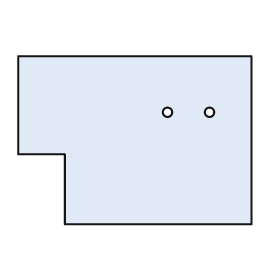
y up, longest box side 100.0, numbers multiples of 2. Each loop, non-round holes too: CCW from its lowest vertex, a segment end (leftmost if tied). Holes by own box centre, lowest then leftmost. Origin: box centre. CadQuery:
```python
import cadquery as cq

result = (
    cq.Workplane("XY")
    .moveTo(-30.0, -36.0)
    .lineTo(50.0, -36.0)
    .lineTo(50.0, 36.0)
    .lineTo(-50.0, 36.0)
    .lineTo(-50.0, -6.0)
    .lineTo(-30.0, -6.0)
    .close()
    .moveTo(14.0, 12.0)
    .circle(2.0)
    .moveTo(32.0, 12.0)
    .circle(2.0)
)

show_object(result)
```